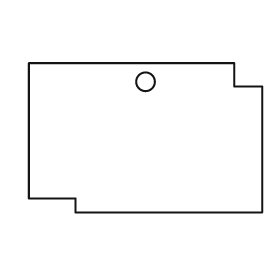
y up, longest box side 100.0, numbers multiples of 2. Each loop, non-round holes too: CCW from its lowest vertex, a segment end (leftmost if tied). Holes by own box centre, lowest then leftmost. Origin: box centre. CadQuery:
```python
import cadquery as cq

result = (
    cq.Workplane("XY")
    .moveTo(-30.0, -32.0)
    .lineTo(50.0, -32.0)
    .lineTo(50.0, 22.0)
    .lineTo(38.0, 22.0)
    .lineTo(38.0, 32.0)
    .lineTo(-50.0, 32.0)
    .lineTo(-50.0, -26.0)
    .lineTo(-30.0, -26.0)
    .close()
    .moveTo(0.0, 24.0)
    .circle(4.0)
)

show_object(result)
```